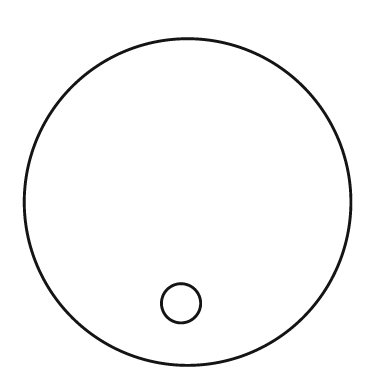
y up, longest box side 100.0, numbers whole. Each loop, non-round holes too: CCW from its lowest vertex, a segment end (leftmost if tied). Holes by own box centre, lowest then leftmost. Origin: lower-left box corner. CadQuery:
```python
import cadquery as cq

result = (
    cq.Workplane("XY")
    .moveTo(50.0, 50.0)
    .circle(50.0)
    .moveTo(48.0, 19.0)
    .circle(6.0)
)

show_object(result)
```